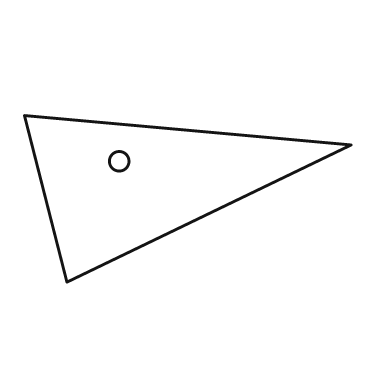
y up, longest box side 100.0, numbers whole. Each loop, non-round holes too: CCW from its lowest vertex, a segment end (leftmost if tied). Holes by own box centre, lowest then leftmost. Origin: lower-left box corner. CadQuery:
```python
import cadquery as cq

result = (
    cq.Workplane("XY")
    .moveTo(13.0, 0.0)
    .lineTo(100.0, 42.0)
    .lineTo(0.0, 51.0)
    .close()
    .moveTo(29.0, 37.0)
    .circle(3.0)
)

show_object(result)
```